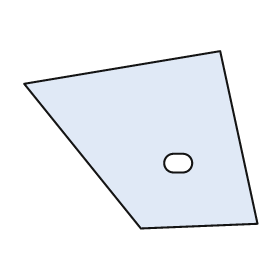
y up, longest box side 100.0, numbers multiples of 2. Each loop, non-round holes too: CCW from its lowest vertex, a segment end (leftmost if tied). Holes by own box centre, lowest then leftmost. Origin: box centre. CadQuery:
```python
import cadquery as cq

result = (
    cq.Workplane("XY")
    .moveTo(0.0, -38.0)
    .lineTo(50.0, -36.0)
    .lineTo(34.0, 38.0)
    .lineTo(-50.0, 24.0)
    .close()
    .moveTo(14.0, -14.0)
    .lineTo(18.0, -14.0)
    .threePointArc((22.0, -10.0), (18.0, -6.0))
    .lineTo(14.0, -6.0)
    .threePointArc((10.0, -10.0), (14.0, -14.0))
    .close()
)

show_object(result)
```